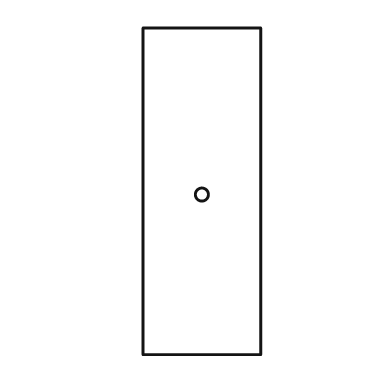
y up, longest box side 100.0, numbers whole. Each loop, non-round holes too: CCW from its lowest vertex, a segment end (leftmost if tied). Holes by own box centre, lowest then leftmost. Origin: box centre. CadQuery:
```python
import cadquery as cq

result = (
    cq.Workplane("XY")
    .moveTo(-18.0, -50.0)
    .lineTo(18.0, -50.0)
    .lineTo(18.0, 50.0)
    .lineTo(-18.0, 50.0)
    .close()
    .moveTo(0.0, -1.0)
    .circle(2.0)
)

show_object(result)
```